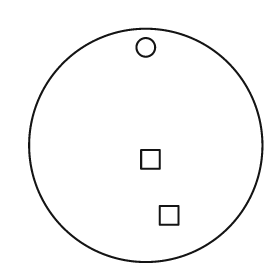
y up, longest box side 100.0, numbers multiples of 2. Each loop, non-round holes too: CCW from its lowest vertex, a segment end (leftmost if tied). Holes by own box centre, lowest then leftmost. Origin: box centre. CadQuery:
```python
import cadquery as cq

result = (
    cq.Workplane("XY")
    .moveTo(0.0, 0.0)
    .circle(50.0)
    .moveTo(6.0, -34.0)
    .lineTo(14.0, -34.0)
    .lineTo(14.0, -26.0)
    .lineTo(6.0, -26.0)
    .close()
    .moveTo(-2.0, -10.0)
    .lineTo(6.0, -10.0)
    .lineTo(6.0, -2.0)
    .lineTo(-2.0, -2.0)
    .close()
    .moveTo(0.0, 42.0)
    .circle(4.0)
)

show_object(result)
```